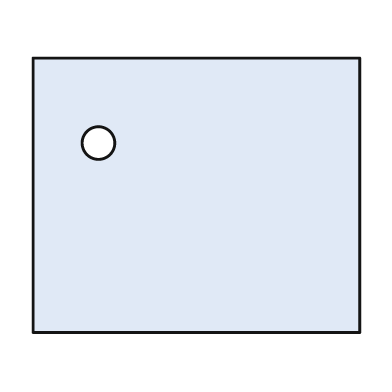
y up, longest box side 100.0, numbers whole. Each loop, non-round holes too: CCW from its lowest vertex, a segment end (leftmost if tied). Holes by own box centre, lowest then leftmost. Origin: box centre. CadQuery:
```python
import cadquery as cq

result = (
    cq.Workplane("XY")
    .moveTo(-50.0, -42.0)
    .lineTo(50.0, -42.0)
    .lineTo(50.0, 42.0)
    .lineTo(-50.0, 42.0)
    .close()
    .moveTo(-30.0, 16.0)
    .circle(5.0)
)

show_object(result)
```